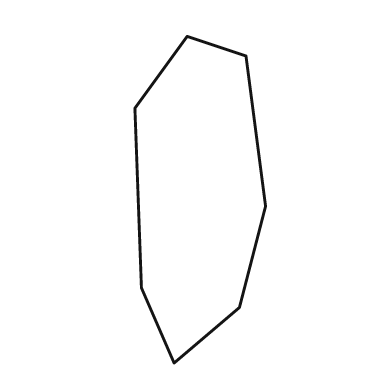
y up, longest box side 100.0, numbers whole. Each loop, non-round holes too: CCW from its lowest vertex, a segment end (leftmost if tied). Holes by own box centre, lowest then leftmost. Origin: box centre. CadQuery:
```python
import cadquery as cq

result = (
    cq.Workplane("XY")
    .moveTo(-8.0, -50.0)
    .lineTo(12.0, -33.0)
    .lineTo(20.0, -2.0)
    .lineTo(14.0, 44.0)
    .lineTo(-4.0, 50.0)
    .lineTo(-20.0, 28.0)
    .lineTo(-18.0, -27.0)
    .close()
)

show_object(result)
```